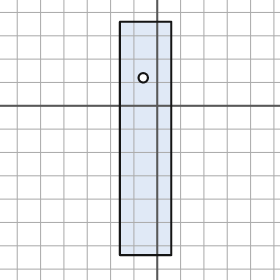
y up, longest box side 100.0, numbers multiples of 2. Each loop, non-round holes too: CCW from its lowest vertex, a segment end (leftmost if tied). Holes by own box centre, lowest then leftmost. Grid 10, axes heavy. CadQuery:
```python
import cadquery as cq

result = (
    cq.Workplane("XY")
    .moveTo(-16.0, -64.0)
    .lineTo(6.0, -64.0)
    .lineTo(6.0, 36.0)
    .lineTo(-16.0, 36.0)
    .close()
    .moveTo(-6.0, 12.0)
    .circle(2.0)
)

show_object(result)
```